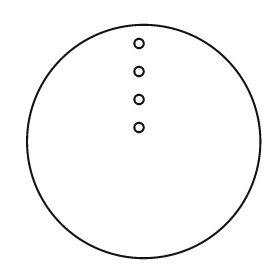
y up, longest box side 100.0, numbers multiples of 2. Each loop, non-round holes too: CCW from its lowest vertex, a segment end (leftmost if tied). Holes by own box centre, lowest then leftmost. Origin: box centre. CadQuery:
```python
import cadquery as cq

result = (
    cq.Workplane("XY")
    .moveTo(0.0, 0.0)
    .circle(50.0)
    .moveTo(-2.0, 6.0)
    .circle(2.0)
    .moveTo(-2.0, 18.0)
    .circle(2.0)
    .moveTo(-2.0, 30.0)
    .circle(2.0)
    .moveTo(-2.0, 42.0)
    .circle(2.0)
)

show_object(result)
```